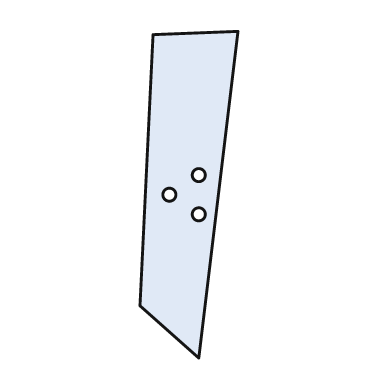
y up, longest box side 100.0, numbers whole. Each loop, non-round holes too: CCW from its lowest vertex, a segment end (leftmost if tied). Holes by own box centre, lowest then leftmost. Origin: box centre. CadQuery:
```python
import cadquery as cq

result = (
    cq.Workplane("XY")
    .moveTo(3.0, -50.0)
    .lineTo(15.0, 50.0)
    .lineTo(-11.0, 49.0)
    .lineTo(-15.0, -34.0)
    .close()
    .moveTo(3.0, -6.0)
    .circle(2.0)
    .moveTo(-6.0, 0.0)
    .circle(2.0)
    .moveTo(3.0, 6.0)
    .circle(2.0)
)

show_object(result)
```